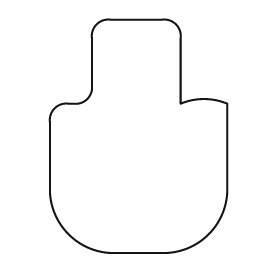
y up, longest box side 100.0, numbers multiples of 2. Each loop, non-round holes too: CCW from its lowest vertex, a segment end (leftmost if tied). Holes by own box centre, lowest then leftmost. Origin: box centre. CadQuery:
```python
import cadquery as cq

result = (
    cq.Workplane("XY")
    .moveTo(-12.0, -50.0)
    .lineTo(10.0, -50.0)
    .threePointArc((30.0, -42.0), (38.0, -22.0))
    .lineTo(38.0, 14.0)
    .threePointArc((28.0, 16.0), (18.0, 14.0))
    .lineTo(18.0, 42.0)
    .threePointArc((16.0, 48.0), (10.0, 50.0))
    .lineTo(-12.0, 50.0)
    .threePointArc((-18.0, 48.0), (-20.0, 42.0))
    .lineTo(-20.0, 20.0)
    .threePointArc((-22.0, 16.0), (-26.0, 14.0))
    .lineTo(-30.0, 14.0)
    .threePointArc((-36.0, 12.0), (-38.0, 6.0))
    .lineTo(-38.0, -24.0)
    .threePointArc((-30.0, -42.0), (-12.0, -50.0))
    .close()
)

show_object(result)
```